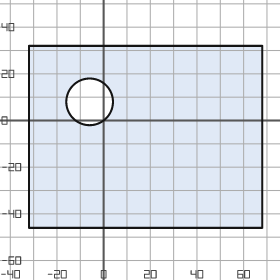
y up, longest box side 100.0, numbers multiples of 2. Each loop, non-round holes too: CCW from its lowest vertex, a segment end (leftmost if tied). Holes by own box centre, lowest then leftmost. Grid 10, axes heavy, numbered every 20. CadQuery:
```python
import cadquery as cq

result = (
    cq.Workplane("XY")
    .moveTo(-32.0, -46.0)
    .lineTo(68.0, -46.0)
    .lineTo(68.0, 32.0)
    .lineTo(-32.0, 32.0)
    .close()
    .moveTo(-6.0, 8.0)
    .circle(10.0)
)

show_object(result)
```